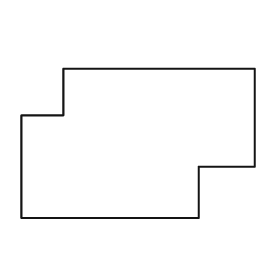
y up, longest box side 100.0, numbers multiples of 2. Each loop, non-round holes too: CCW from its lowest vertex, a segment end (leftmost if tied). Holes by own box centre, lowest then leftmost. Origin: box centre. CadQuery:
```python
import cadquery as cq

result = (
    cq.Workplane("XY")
    .moveTo(-50.0, -32.0)
    .lineTo(26.0, -32.0)
    .lineTo(26.0, -10.0)
    .lineTo(50.0, -10.0)
    .lineTo(50.0, 32.0)
    .lineTo(-32.0, 32.0)
    .lineTo(-32.0, 12.0)
    .lineTo(-50.0, 12.0)
    .close()
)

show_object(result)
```